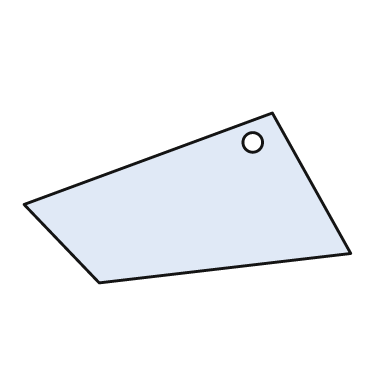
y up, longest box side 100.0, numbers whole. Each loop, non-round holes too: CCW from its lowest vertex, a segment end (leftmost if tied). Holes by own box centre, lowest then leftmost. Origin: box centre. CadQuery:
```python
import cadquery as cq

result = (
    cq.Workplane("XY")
    .moveTo(-27.0, -26.0)
    .lineTo(50.0, -17.0)
    .lineTo(26.0, 26.0)
    .lineTo(-50.0, -2.0)
    .close()
    .moveTo(20.0, 17.0)
    .circle(3.0)
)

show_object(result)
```